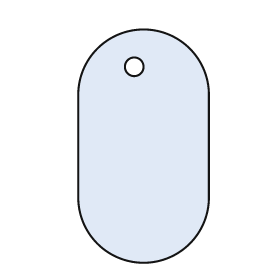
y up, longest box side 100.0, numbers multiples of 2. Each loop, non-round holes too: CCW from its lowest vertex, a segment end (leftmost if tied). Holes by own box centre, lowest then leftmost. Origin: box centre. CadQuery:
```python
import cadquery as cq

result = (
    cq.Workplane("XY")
    .moveTo(-28.0, -22.0)
    .threePointArc((0.0, -50.0), (28.0, -22.0))
    .lineTo(28.0, 22.0)
    .threePointArc((0.0, 50.0), (-28.0, 22.0))
    .close()
    .moveTo(-4.0, 34.0)
    .circle(4.0)
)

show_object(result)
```